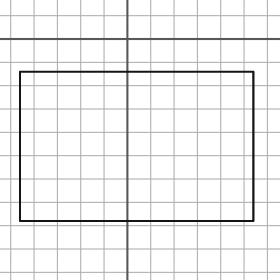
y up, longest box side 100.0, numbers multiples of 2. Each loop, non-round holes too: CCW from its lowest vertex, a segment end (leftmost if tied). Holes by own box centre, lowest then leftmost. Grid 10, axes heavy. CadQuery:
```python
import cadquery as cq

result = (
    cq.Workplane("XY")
    .moveTo(-46.0, -78.0)
    .lineTo(54.0, -78.0)
    .lineTo(54.0, -14.0)
    .lineTo(-46.0, -14.0)
    .close()
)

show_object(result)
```